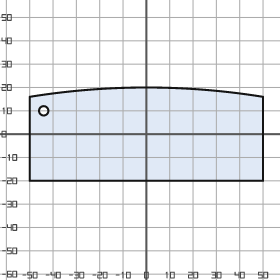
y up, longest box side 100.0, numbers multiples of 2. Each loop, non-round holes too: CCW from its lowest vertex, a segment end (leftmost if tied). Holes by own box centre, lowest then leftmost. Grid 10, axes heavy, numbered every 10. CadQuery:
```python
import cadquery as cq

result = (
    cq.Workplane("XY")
    .moveTo(-50.0, -20.0)
    .lineTo(50.0, -20.0)
    .lineTo(50.0, 16.0)
    .threePointArc((0.0, 20.0), (-50.0, 16.0))
    .close()
    .moveTo(-44.0, 10.0)
    .circle(2.0)
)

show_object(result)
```